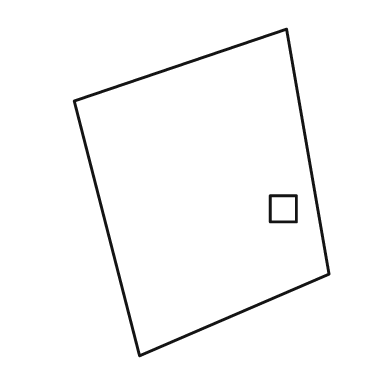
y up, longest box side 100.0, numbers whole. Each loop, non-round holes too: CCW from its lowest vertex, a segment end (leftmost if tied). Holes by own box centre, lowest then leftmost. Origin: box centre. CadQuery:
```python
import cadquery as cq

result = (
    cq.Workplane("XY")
    .moveTo(-19.0, -50.0)
    .lineTo(39.0, -25.0)
    .lineTo(26.0, 50.0)
    .lineTo(-39.0, 28.0)
    .close()
    .moveTo(21.0, -9.0)
    .lineTo(29.0, -9.0)
    .lineTo(29.0, -1.0)
    .lineTo(21.0, -1.0)
    .close()
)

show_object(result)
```